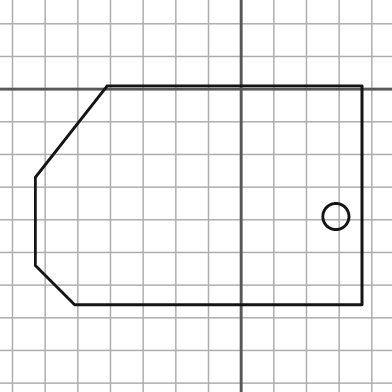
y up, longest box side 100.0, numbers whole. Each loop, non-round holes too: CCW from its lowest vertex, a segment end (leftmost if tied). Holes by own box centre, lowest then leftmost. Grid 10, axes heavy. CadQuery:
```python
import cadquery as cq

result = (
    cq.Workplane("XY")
    .moveTo(-51.0, -66.0)
    .lineTo(37.0, -66.0)
    .lineTo(37.0, 1.0)
    .lineTo(-41.0, 1.0)
    .lineTo(-63.0, -27.0)
    .lineTo(-63.0, -54.0)
    .close()
    .moveTo(29.0, -39.0)
    .circle(4.0)
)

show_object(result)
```